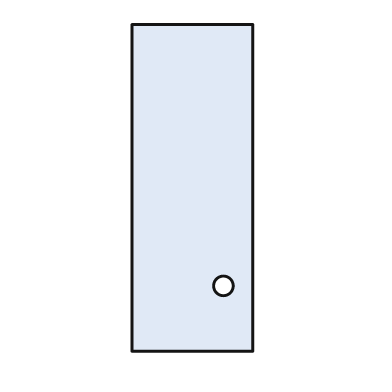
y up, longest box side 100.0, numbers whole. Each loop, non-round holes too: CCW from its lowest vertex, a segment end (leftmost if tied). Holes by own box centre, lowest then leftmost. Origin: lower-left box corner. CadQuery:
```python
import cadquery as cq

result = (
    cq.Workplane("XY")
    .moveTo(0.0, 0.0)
    .lineTo(37.0, 0.0)
    .lineTo(37.0, 100.0)
    .lineTo(0.0, 100.0)
    .close()
    .moveTo(28.0, 20.0)
    .circle(3.0)
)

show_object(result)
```